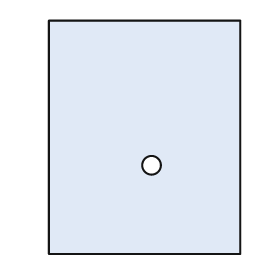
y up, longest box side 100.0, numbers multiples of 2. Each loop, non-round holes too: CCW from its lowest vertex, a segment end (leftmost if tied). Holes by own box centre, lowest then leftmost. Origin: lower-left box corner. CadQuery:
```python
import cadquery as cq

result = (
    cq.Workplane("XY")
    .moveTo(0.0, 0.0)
    .lineTo(82.0, 0.0)
    .lineTo(82.0, 100.0)
    .lineTo(0.0, 100.0)
    .close()
    .moveTo(44.0, 38.0)
    .circle(4.0)
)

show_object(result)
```